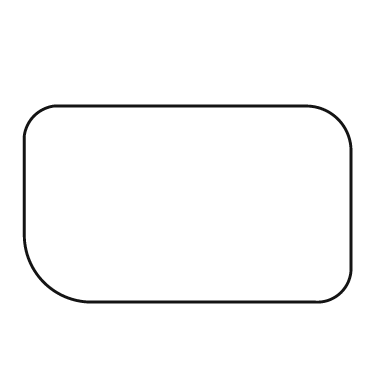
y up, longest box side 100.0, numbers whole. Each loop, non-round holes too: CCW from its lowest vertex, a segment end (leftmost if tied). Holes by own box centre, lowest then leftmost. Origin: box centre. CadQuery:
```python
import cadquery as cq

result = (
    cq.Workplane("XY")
    .moveTo(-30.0, -30.0)
    .lineTo(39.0, -30.0)
    .threePointArc((47.0, -27.0), (50.0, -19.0))
    .lineTo(50.0, 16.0)
    .threePointArc((46.0, 26.0), (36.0, 30.0))
    .lineTo(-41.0, 30.0)
    .threePointArc((-47.0, 27.0), (-50.0, 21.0))
    .lineTo(-50.0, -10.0)
    .threePointArc((-44.0, -24.0), (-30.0, -30.0))
    .close()
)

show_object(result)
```